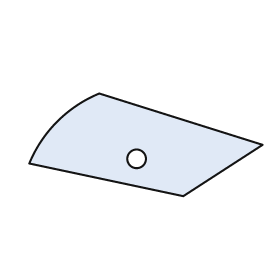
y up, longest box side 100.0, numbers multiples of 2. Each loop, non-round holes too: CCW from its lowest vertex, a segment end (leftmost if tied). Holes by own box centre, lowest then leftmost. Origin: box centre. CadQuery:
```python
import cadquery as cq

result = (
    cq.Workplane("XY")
    .moveTo(16.0, -22.0)
    .lineTo(50.0, 0.0)
    .lineTo(-20.0, 22.0)
    .threePointArc((-38.0, 10.0), (-50.0, -8.0))
    .close()
    .moveTo(-4.0, -6.0)
    .circle(4.0)
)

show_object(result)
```